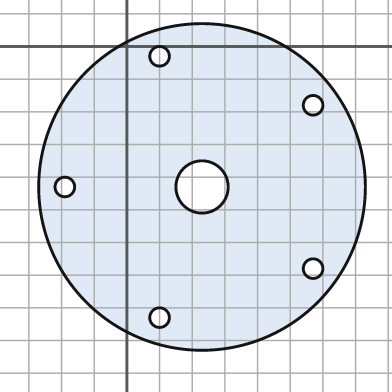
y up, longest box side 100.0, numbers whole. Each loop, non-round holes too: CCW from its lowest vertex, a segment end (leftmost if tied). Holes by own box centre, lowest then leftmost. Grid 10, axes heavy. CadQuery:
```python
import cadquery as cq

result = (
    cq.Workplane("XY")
    .moveTo(23.0, -43.0)
    .circle(50.0)
    .moveTo(10.0, -83.0)
    .circle(3.0)
    .moveTo(57.0, -68.0)
    .circle(3.0)
    .moveTo(-19.0, -43.0)
    .circle(3.0)
    .moveTo(23.0, -43.0)
    .circle(8.0)
    .moveTo(57.0, -18.0)
    .circle(3.0)
    .moveTo(10.0, -3.0)
    .circle(3.0)
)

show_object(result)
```